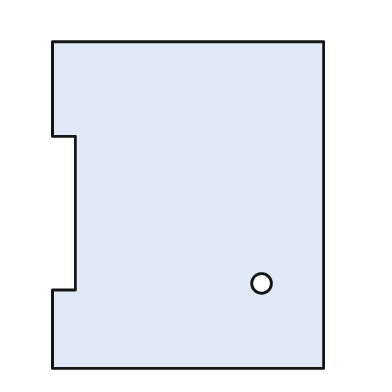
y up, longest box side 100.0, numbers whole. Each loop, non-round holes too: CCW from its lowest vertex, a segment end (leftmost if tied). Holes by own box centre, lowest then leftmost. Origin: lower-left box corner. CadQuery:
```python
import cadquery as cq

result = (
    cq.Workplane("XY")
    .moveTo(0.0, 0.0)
    .lineTo(83.0, 0.0)
    .lineTo(83.0, 100.0)
    .lineTo(0.0, 100.0)
    .lineTo(0.0, 71.0)
    .lineTo(7.0, 71.0)
    .lineTo(7.0, 24.0)
    .lineTo(0.0, 24.0)
    .close()
    .moveTo(64.0, 26.0)
    .circle(3.0)
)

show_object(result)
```